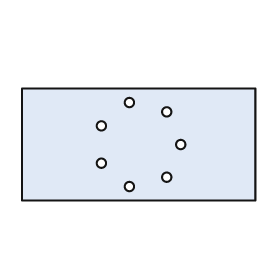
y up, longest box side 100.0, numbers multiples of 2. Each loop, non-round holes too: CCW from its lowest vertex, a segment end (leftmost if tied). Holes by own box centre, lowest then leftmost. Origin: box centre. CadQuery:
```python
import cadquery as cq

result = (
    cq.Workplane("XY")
    .moveTo(-50.0, -24.0)
    .lineTo(50.0, -24.0)
    .lineTo(50.0, 24.0)
    .lineTo(-50.0, 24.0)
    .close()
    .moveTo(-4.0, -18.0)
    .circle(2.0)
    .moveTo(12.0, -14.0)
    .circle(2.0)
    .moveTo(-16.0, -8.0)
    .circle(2.0)
    .moveTo(18.0, 0.0)
    .circle(2.0)
    .moveTo(-16.0, 8.0)
    .circle(2.0)
    .moveTo(12.0, 14.0)
    .circle(2.0)
    .moveTo(-4.0, 18.0)
    .circle(2.0)
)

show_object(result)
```